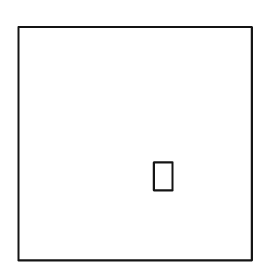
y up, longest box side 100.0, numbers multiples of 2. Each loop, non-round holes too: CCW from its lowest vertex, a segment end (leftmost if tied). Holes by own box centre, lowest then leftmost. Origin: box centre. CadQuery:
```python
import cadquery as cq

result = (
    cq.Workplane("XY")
    .moveTo(-50.0, -50.0)
    .lineTo(50.0, -50.0)
    .lineTo(50.0, 50.0)
    .lineTo(-50.0, 50.0)
    .close()
    .moveTo(8.0, -20.0)
    .lineTo(16.0, -20.0)
    .lineTo(16.0, -8.0)
    .lineTo(8.0, -8.0)
    .close()
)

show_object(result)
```